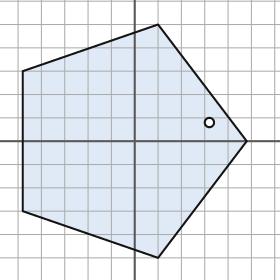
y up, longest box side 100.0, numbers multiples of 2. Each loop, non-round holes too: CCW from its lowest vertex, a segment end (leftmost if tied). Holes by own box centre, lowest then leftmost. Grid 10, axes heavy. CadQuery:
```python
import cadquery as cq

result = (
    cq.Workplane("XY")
    .moveTo(10.0, -50.0)
    .lineTo(48.0, 0.0)
    .lineTo(10.0, 50.0)
    .lineTo(-48.0, 30.0)
    .lineTo(-48.0, -30.0)
    .close()
    .moveTo(32.0, 8.0)
    .circle(2.0)
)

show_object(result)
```